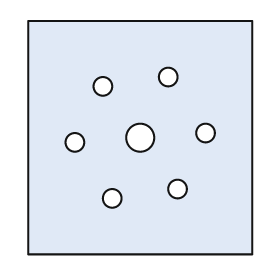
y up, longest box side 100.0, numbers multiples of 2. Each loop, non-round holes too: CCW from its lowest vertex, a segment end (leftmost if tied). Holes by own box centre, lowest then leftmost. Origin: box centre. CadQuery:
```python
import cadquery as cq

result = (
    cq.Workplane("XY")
    .moveTo(-48.0, -50.0)
    .lineTo(48.0, -50.0)
    .lineTo(48.0, 50.0)
    .lineTo(-48.0, 50.0)
    .close()
    .moveTo(-12.0, -26.0)
    .circle(4.0)
    .moveTo(16.0, -22.0)
    .circle(4.0)
    .moveTo(-28.0, -2.0)
    .circle(4.0)
    .moveTo(0.0, 0.0)
    .circle(6.0)
    .moveTo(28.0, 2.0)
    .circle(4.0)
    .moveTo(-16.0, 22.0)
    .circle(4.0)
    .moveTo(12.0, 26.0)
    .circle(4.0)
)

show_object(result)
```